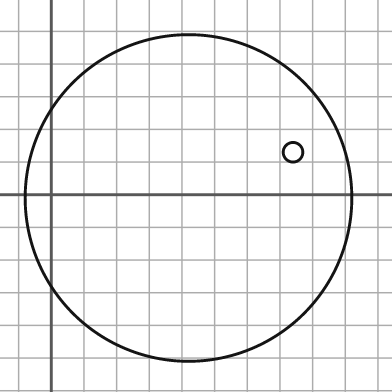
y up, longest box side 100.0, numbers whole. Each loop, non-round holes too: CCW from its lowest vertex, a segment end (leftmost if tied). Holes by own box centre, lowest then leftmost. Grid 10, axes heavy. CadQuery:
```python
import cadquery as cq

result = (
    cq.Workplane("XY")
    .moveTo(42.0, -1.0)
    .circle(50.0)
    .moveTo(74.0, 13.0)
    .circle(3.0)
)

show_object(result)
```